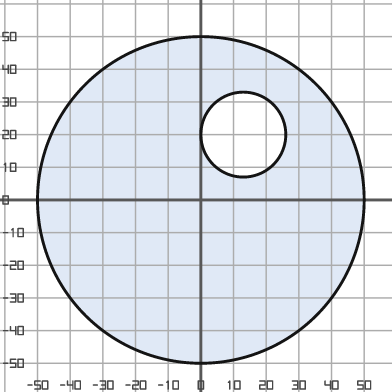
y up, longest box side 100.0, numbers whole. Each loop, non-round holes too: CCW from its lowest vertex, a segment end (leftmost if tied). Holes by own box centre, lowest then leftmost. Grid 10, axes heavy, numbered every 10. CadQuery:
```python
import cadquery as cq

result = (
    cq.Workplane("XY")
    .moveTo(0.0, 0.0)
    .circle(50.0)
    .moveTo(13.0, 20.0)
    .circle(13.0)
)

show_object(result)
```